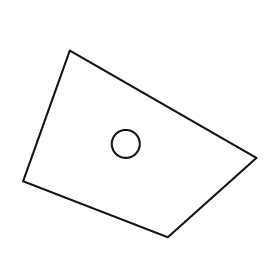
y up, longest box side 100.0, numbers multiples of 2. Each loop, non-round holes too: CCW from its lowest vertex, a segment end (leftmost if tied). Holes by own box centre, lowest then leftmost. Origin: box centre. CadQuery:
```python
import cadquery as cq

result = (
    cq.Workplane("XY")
    .moveTo(12.0, -40.0)
    .lineTo(50.0, -6.0)
    .lineTo(-30.0, 40.0)
    .lineTo(-50.0, -16.0)
    .close()
    .moveTo(-6.0, 0.0)
    .circle(6.0)
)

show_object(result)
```